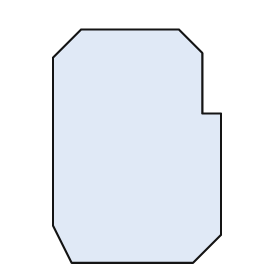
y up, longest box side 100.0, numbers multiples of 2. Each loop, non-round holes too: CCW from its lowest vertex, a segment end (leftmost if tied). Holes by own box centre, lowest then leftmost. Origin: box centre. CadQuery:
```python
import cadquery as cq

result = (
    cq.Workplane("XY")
    .moveTo(-28.0, -50.0)
    .lineTo(24.0, -50.0)
    .lineTo(36.0, -38.0)
    .lineTo(36.0, 14.0)
    .lineTo(28.0, 14.0)
    .lineTo(28.0, 40.0)
    .lineTo(18.0, 50.0)
    .lineTo(-24.0, 50.0)
    .lineTo(-36.0, 38.0)
    .lineTo(-36.0, -34.0)
    .close()
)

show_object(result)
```